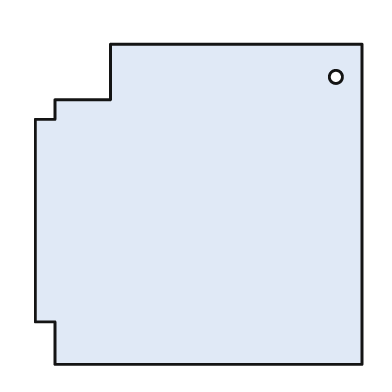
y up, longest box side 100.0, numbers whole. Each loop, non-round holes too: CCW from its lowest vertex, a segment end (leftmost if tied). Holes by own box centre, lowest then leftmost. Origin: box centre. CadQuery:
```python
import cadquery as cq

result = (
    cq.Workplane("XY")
    .moveTo(-44.0, -49.0)
    .lineTo(50.0, -49.0)
    .lineTo(50.0, 49.0)
    .lineTo(-27.0, 49.0)
    .lineTo(-27.0, 32.0)
    .lineTo(-44.0, 32.0)
    .lineTo(-44.0, 26.0)
    .lineTo(-50.0, 26.0)
    .lineTo(-50.0, -36.0)
    .lineTo(-44.0, -36.0)
    .close()
    .moveTo(42.0, 39.0)
    .circle(2.0)
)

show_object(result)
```